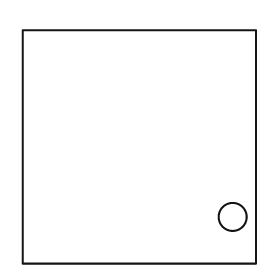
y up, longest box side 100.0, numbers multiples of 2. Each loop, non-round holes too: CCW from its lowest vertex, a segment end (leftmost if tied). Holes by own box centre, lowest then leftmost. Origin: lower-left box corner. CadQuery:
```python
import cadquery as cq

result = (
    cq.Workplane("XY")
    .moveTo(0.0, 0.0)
    .lineTo(100.0, 0.0)
    .lineTo(100.0, 100.0)
    .lineTo(0.0, 100.0)
    .close()
    .moveTo(90.0, 20.0)
    .circle(6.0)
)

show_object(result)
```